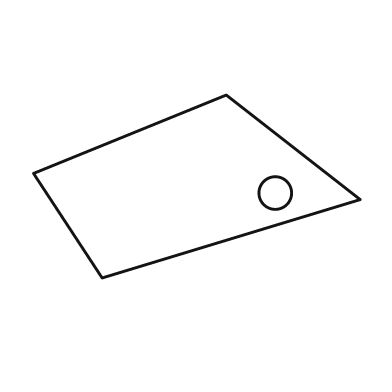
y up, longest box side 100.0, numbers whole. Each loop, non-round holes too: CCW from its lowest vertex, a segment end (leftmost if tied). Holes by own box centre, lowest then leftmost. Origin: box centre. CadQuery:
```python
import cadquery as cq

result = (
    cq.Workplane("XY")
    .moveTo(-29.0, -28.0)
    .lineTo(50.0, -4.0)
    .lineTo(9.0, 28.0)
    .lineTo(-50.0, 4.0)
    .close()
    .moveTo(24.0, -2.0)
    .circle(5.0)
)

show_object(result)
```